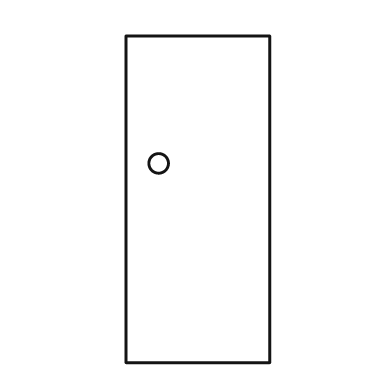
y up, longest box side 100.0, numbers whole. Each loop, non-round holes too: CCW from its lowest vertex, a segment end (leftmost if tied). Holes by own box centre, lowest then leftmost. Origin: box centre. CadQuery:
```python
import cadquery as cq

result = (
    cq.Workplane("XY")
    .moveTo(-22.0, -50.0)
    .lineTo(22.0, -50.0)
    .lineTo(22.0, 50.0)
    .lineTo(-22.0, 50.0)
    .close()
    .moveTo(-12.0, 11.0)
    .circle(3.0)
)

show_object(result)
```